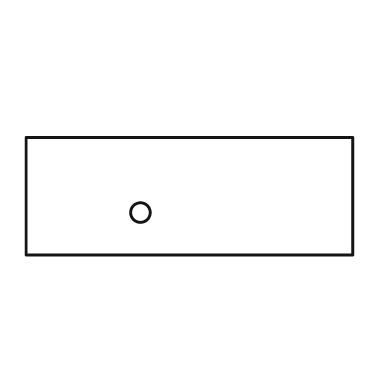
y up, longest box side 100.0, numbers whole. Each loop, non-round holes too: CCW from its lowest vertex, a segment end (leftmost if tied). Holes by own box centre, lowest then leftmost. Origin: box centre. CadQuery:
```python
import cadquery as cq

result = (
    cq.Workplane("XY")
    .moveTo(-50.0, -18.0)
    .lineTo(50.0, -18.0)
    .lineTo(50.0, 18.0)
    .lineTo(-50.0, 18.0)
    .close()
    .moveTo(-15.0, -5.0)
    .circle(3.0)
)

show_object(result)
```